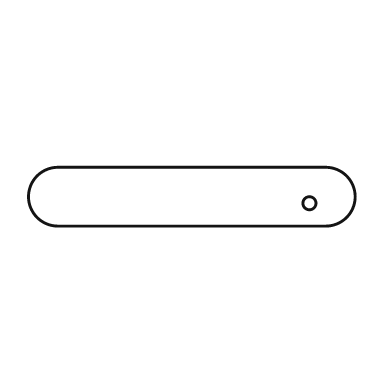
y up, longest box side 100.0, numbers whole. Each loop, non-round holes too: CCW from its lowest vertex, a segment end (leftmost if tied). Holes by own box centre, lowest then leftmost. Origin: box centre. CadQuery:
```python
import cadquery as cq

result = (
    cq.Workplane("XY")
    .moveTo(-41.0, -9.0)
    .lineTo(41.0, -9.0)
    .threePointArc((50.0, 0.0), (41.0, 9.0))
    .lineTo(-41.0, 9.0)
    .threePointArc((-50.0, 0.0), (-41.0, -9.0))
    .close()
    .moveTo(36.0, -2.0)
    .circle(2.0)
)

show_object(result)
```